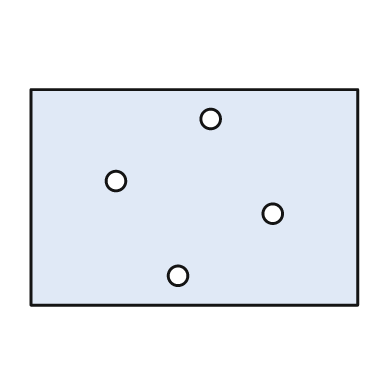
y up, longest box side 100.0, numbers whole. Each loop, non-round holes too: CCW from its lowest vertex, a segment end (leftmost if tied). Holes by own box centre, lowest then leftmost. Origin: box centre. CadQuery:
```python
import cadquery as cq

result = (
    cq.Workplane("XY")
    .moveTo(-50.0, -33.0)
    .lineTo(50.0, -33.0)
    .lineTo(50.0, 33.0)
    .lineTo(-50.0, 33.0)
    .close()
    .moveTo(-5.0, -24.0)
    .circle(3.0)
    .moveTo(24.0, -5.0)
    .circle(3.0)
    .moveTo(-24.0, 5.0)
    .circle(3.0)
    .moveTo(5.0, 24.0)
    .circle(3.0)
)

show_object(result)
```